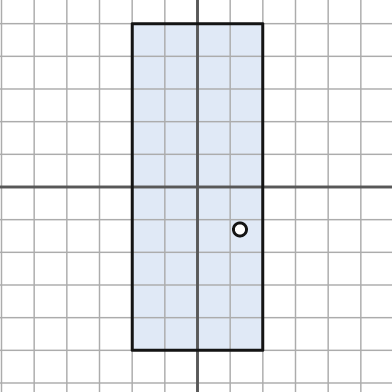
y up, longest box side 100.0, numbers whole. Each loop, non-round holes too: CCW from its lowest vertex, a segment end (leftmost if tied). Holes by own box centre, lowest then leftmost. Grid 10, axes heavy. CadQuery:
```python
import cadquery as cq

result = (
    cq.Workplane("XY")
    .moveTo(-20.0, -50.0)
    .lineTo(20.0, -50.0)
    .lineTo(20.0, 50.0)
    .lineTo(-20.0, 50.0)
    .close()
    .moveTo(13.0, -13.0)
    .circle(2.0)
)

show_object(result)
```